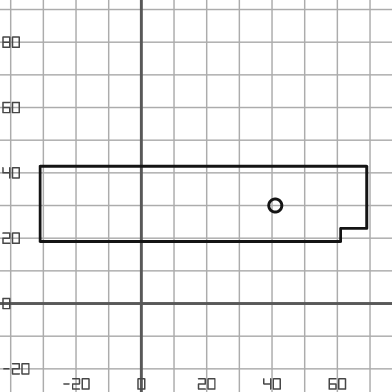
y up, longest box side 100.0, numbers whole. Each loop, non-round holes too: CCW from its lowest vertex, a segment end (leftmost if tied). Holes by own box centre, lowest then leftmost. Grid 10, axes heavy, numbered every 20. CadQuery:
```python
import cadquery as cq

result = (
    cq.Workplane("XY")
    .moveTo(-31.0, 19.0)
    .lineTo(61.0, 19.0)
    .lineTo(61.0, 23.0)
    .lineTo(69.0, 23.0)
    .lineTo(69.0, 42.0)
    .lineTo(-31.0, 42.0)
    .close()
    .moveTo(41.0, 30.0)
    .circle(2.0)
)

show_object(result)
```